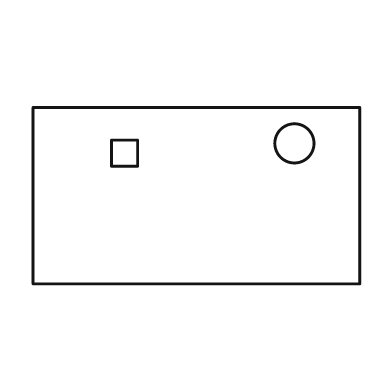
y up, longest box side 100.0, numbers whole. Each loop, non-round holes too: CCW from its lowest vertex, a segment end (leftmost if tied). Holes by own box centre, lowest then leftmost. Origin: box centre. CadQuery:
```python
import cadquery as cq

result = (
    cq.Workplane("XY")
    .moveTo(-50.0, -27.0)
    .lineTo(50.0, -27.0)
    .lineTo(50.0, 27.0)
    .lineTo(-50.0, 27.0)
    .close()
    .moveTo(-26.0, 9.0)
    .lineTo(-18.0, 9.0)
    .lineTo(-18.0, 17.0)
    .lineTo(-26.0, 17.0)
    .close()
    .moveTo(30.0, 16.0)
    .circle(6.0)
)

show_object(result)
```